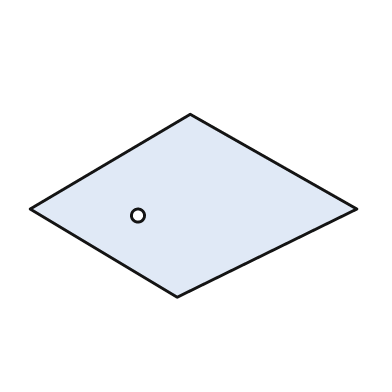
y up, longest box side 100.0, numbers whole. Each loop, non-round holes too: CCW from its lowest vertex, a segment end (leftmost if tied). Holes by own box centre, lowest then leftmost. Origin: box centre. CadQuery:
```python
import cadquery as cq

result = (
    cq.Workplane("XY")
    .moveTo(-5.0, -28.0)
    .lineTo(50.0, -1.0)
    .lineTo(-1.0, 28.0)
    .lineTo(-50.0, -1.0)
    .close()
    .moveTo(-17.0, -3.0)
    .circle(2.0)
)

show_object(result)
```